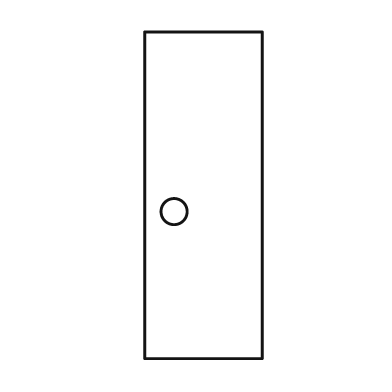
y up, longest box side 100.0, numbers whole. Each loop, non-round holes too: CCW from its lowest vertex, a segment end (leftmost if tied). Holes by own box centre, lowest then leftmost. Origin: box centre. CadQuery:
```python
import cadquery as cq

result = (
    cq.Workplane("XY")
    .moveTo(-18.0, -50.0)
    .lineTo(18.0, -50.0)
    .lineTo(18.0, 50.0)
    .lineTo(-18.0, 50.0)
    .close()
    .moveTo(-9.0, -5.0)
    .circle(4.0)
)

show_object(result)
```